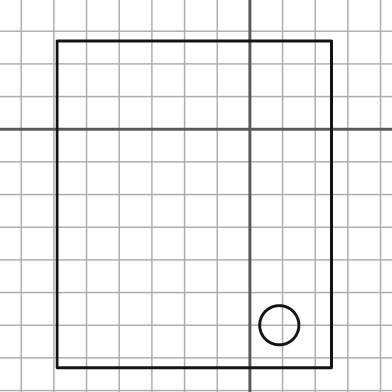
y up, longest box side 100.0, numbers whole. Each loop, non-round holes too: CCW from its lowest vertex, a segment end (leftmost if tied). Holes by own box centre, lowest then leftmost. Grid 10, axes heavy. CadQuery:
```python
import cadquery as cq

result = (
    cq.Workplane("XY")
    .moveTo(-59.0, -73.0)
    .lineTo(25.0, -73.0)
    .lineTo(25.0, 27.0)
    .lineTo(-59.0, 27.0)
    .close()
    .moveTo(9.0, -60.0)
    .circle(6.0)
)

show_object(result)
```